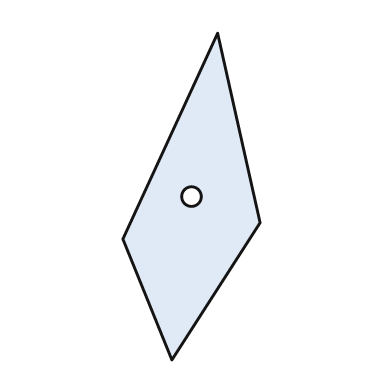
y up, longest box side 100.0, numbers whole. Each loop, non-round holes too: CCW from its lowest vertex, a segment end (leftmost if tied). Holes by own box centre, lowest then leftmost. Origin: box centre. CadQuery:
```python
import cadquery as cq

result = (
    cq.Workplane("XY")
    .moveTo(-6.0, -50.0)
    .lineTo(21.0, -8.0)
    .lineTo(8.0, 50.0)
    .lineTo(-21.0, -13.0)
    .close()
    .moveTo(0.0, 0.0)
    .circle(3.0)
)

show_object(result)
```